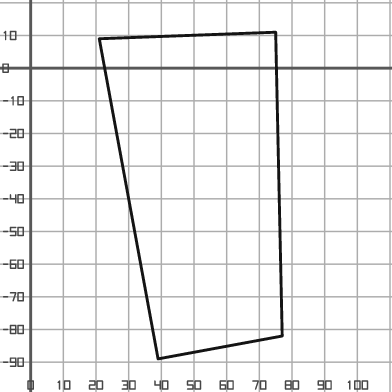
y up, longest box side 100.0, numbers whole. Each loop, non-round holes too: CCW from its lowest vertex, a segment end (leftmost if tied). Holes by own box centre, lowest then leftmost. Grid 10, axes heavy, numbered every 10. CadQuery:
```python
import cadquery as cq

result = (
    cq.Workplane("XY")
    .moveTo(39.0, -89.0)
    .lineTo(77.0, -82.0)
    .lineTo(75.0, 11.0)
    .lineTo(21.0, 9.0)
    .close()
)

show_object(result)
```